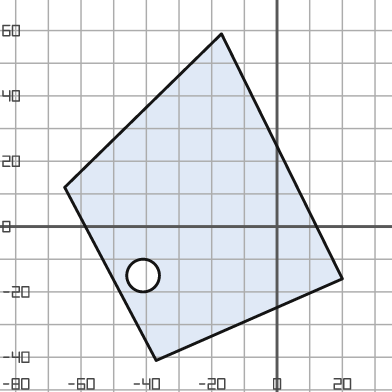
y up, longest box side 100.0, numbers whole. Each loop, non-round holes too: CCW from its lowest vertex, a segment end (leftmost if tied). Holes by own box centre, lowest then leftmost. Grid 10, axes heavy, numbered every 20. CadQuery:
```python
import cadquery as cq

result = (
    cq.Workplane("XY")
    .moveTo(-37.0, -41.0)
    .lineTo(20.0, -16.0)
    .lineTo(-17.0, 59.0)
    .lineTo(-65.0, 12.0)
    .close()
    .moveTo(-41.0, -15.0)
    .circle(5.0)
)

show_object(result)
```